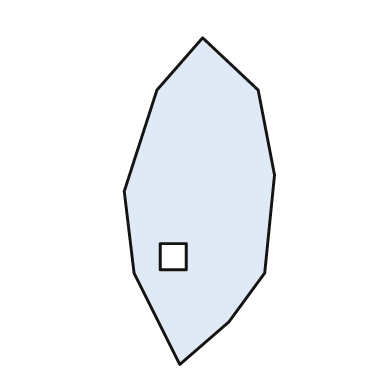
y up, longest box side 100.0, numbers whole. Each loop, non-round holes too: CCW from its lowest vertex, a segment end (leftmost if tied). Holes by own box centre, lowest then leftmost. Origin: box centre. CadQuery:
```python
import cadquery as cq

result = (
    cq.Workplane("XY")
    .moveTo(-6.0, -50.0)
    .lineTo(9.0, -37.0)
    .lineTo(20.0, -22.0)
    .lineTo(23.0, 8.0)
    .lineTo(18.0, 34.0)
    .lineTo(1.0, 50.0)
    .lineTo(-13.0, 34.0)
    .lineTo(-23.0, 3.0)
    .lineTo(-20.0, -22.0)
    .close()
    .moveTo(-12.0, -21.0)
    .lineTo(-4.0, -21.0)
    .lineTo(-4.0, -13.0)
    .lineTo(-12.0, -13.0)
    .close()
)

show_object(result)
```